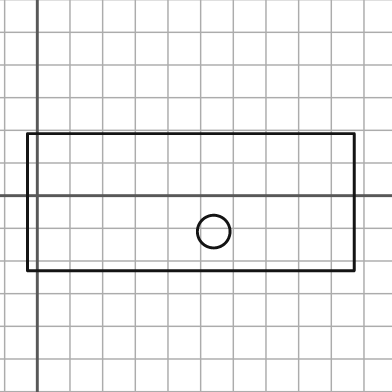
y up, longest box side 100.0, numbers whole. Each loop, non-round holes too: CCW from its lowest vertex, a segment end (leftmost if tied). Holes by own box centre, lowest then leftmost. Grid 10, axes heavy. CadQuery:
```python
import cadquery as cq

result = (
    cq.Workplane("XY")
    .moveTo(-3.0, -23.0)
    .lineTo(97.0, -23.0)
    .lineTo(97.0, 19.0)
    .lineTo(-3.0, 19.0)
    .close()
    .moveTo(54.0, -11.0)
    .circle(5.0)
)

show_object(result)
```